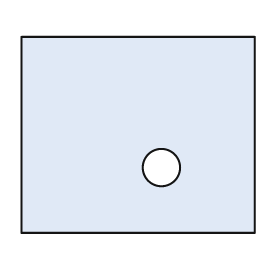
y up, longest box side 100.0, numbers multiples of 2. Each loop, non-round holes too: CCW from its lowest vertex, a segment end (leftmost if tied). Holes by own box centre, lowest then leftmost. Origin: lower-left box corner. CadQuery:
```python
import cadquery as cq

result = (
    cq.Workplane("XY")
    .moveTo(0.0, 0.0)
    .lineTo(100.0, 0.0)
    .lineTo(100.0, 84.0)
    .lineTo(0.0, 84.0)
    .close()
    .moveTo(60.0, 28.0)
    .circle(8.0)
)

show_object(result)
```